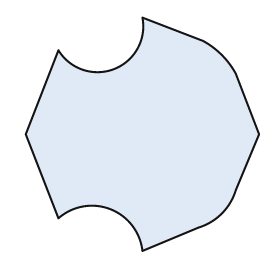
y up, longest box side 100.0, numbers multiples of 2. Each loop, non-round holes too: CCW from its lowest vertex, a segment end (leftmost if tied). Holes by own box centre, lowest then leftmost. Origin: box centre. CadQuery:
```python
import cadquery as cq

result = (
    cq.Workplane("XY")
    .moveTo(0.0, -50.0)
    .lineTo(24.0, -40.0)
    .threePointArc((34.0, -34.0), (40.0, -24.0))
    .lineTo(50.0, 0.0)
    .lineTo(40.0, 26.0)
    .threePointArc((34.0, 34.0), (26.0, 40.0))
    .lineTo(0.0, 50.0)
    .threePointArc((-12.0, 28.0), (-36.0, 36.0))
    .lineTo(-50.0, 0.0)
    .lineTo(-36.0, -36.0)
    .threePointArc((-14.0, -32.0), (0.0, -50.0))
    .close()
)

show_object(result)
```